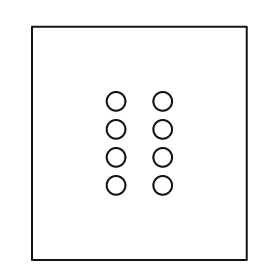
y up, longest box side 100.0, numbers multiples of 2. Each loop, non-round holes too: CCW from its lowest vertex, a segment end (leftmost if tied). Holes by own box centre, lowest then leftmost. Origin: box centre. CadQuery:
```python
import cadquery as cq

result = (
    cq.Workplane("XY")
    .moveTo(-46.0, -50.0)
    .lineTo(46.0, -50.0)
    .lineTo(46.0, 50.0)
    .lineTo(-46.0, 50.0)
    .close()
    .moveTo(-10.0, -18.0)
    .circle(4.0)
    .moveTo(10.0, -18.0)
    .circle(4.0)
    .moveTo(-10.0, -6.0)
    .circle(4.0)
    .moveTo(10.0, -6.0)
    .circle(4.0)
    .moveTo(-10.0, 6.0)
    .circle(4.0)
    .moveTo(10.0, 6.0)
    .circle(4.0)
    .moveTo(-10.0, 18.0)
    .circle(4.0)
    .moveTo(10.0, 18.0)
    .circle(4.0)
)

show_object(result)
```